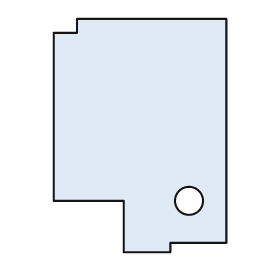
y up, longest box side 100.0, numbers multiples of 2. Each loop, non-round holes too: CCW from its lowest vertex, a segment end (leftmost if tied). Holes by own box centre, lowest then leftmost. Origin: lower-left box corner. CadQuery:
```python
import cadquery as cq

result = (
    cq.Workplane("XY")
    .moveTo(30.0, 0.0)
    .lineTo(50.0, 0.0)
    .lineTo(50.0, 4.0)
    .lineTo(74.0, 4.0)
    .lineTo(74.0, 100.0)
    .lineTo(10.0, 100.0)
    .lineTo(10.0, 94.0)
    .lineTo(0.0, 94.0)
    .lineTo(0.0, 22.0)
    .lineTo(30.0, 22.0)
    .close()
    .moveTo(58.0, 22.0)
    .circle(6.0)
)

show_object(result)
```